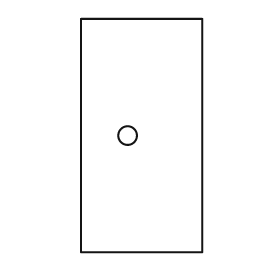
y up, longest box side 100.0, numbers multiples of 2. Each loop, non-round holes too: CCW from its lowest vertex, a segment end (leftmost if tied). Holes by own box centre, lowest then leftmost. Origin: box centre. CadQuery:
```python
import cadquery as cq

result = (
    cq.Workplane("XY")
    .moveTo(-26.0, -50.0)
    .lineTo(26.0, -50.0)
    .lineTo(26.0, 50.0)
    .lineTo(-26.0, 50.0)
    .close()
    .moveTo(-6.0, 0.0)
    .circle(4.0)
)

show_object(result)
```